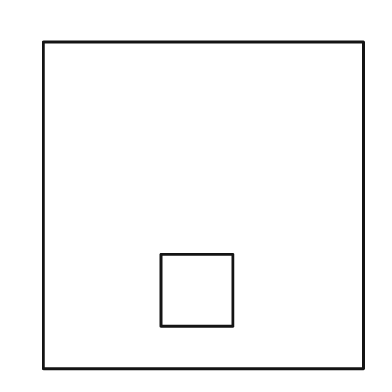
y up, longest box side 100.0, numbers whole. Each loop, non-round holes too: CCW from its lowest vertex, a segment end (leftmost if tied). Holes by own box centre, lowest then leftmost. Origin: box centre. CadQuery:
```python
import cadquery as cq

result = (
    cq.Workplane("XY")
    .moveTo(-49.0, -50.0)
    .lineTo(49.0, -50.0)
    .lineTo(49.0, 50.0)
    .lineTo(-49.0, 50.0)
    .close()
    .moveTo(-13.0, -37.0)
    .lineTo(9.0, -37.0)
    .lineTo(9.0, -15.0)
    .lineTo(-13.0, -15.0)
    .close()
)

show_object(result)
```